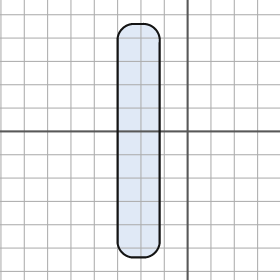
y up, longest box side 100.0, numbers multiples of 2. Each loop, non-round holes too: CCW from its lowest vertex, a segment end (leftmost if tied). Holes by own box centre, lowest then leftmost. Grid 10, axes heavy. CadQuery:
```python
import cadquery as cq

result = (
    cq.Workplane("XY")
    .moveTo(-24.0, -54.0)
    .lineTo(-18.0, -54.0)
    .threePointArc((-14.0, -52.0), (-12.0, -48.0))
    .lineTo(-12.0, 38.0)
    .threePointArc((-14.0, 44.0), (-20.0, 46.0))
    .lineTo(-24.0, 46.0)
    .threePointArc((-28.0, 44.0), (-30.0, 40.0))
    .lineTo(-30.0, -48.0)
    .threePointArc((-28.0, -52.0), (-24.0, -54.0))
    .close()
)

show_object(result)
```